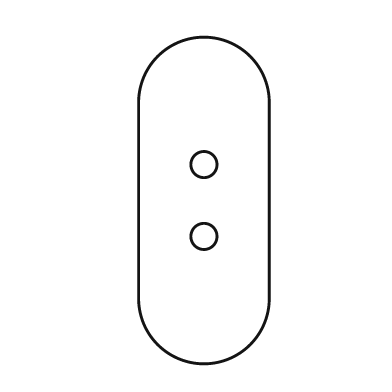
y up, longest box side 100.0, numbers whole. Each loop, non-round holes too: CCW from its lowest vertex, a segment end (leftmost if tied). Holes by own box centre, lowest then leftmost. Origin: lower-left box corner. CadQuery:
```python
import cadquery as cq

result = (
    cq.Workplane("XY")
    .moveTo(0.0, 20.0)
    .threePointArc((20.0, 0.0), (40.0, 20.0))
    .lineTo(40.0, 80.0)
    .threePointArc((20.0, 100.0), (0.0, 80.0))
    .close()
    .moveTo(20.0, 39.0)
    .circle(4.0)
    .moveTo(20.0, 61.0)
    .circle(4.0)
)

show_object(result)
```